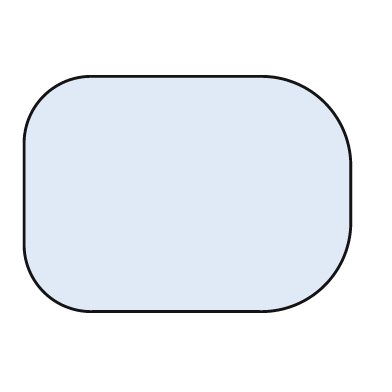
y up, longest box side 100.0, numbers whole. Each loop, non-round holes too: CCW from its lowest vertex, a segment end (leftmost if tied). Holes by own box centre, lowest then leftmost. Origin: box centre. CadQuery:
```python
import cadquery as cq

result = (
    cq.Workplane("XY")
    .moveTo(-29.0, -36.0)
    .lineTo(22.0, -36.0)
    .threePointArc((42.0, -28.0), (50.0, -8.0))
    .lineTo(50.0, 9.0)
    .threePointArc((42.0, 28.0), (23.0, 36.0))
    .lineTo(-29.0, 36.0)
    .threePointArc((-44.0, 30.0), (-50.0, 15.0))
    .lineTo(-50.0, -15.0)
    .threePointArc((-44.0, -30.0), (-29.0, -36.0))
    .close()
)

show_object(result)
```